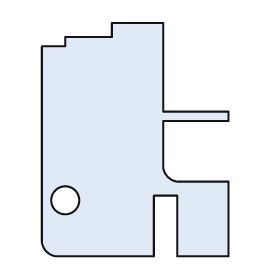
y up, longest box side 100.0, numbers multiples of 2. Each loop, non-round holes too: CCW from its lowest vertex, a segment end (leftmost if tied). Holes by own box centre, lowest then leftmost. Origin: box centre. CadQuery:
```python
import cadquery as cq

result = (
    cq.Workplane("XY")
    .moveTo(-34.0, -50.0)
    .lineTo(8.0, -50.0)
    .lineTo(8.0, -24.0)
    .lineTo(18.0, -24.0)
    .lineTo(18.0, -50.0)
    .lineTo(40.0, -50.0)
    .lineTo(40.0, -18.0)
    .lineTo(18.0, -18.0)
    .threePointArc((14.0, -16.0), (12.0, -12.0))
    .lineTo(12.0, 8.0)
    .lineTo(40.0, 8.0)
    .lineTo(40.0, 12.0)
    .lineTo(12.0, 12.0)
    .lineTo(12.0, 50.0)
    .lineTo(-10.0, 50.0)
    .lineTo(-10.0, 44.0)
    .lineTo(-30.0, 44.0)
    .lineTo(-30.0, 40.0)
    .lineTo(-40.0, 40.0)
    .lineTo(-40.0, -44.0)
    .threePointArc((-38.0, -48.0), (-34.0, -50.0))
    .close()
    .moveTo(-30.0, -26.0)
    .circle(6.0)
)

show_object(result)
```